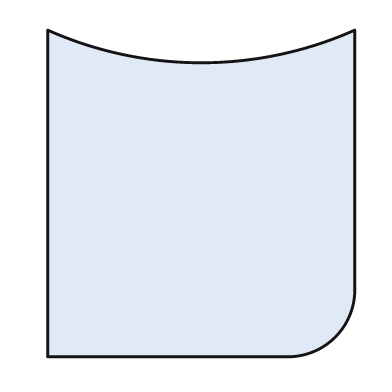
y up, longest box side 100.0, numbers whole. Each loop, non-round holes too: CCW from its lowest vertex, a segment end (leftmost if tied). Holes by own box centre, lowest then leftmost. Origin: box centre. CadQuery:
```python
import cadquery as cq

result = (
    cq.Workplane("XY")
    .moveTo(-47.0, -50.0)
    .lineTo(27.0, -50.0)
    .threePointArc((41.0, -44.0), (47.0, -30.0))
    .lineTo(47.0, 50.0)
    .threePointArc((0.0, 40.0), (-47.0, 50.0))
    .close()
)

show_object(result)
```